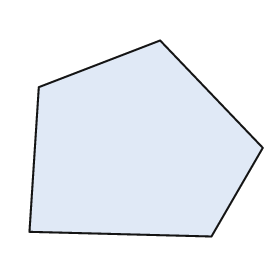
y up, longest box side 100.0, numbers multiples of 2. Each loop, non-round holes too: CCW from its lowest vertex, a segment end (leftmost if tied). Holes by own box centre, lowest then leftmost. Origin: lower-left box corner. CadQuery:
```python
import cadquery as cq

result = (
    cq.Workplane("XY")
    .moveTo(78.0, 0.0)
    .lineTo(100.0, 38.0)
    .lineTo(56.0, 84.0)
    .lineTo(4.0, 64.0)
    .lineTo(0.0, 2.0)
    .close()
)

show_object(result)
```